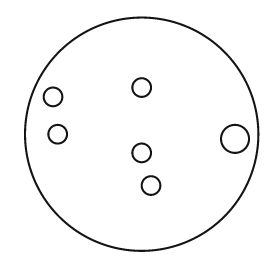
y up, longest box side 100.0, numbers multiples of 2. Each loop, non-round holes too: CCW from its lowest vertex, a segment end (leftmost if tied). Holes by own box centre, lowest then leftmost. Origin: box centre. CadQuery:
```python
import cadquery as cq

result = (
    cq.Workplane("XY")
    .moveTo(0.0, 0.0)
    .circle(50.0)
    .moveTo(4.0, -22.0)
    .circle(4.0)
    .moveTo(0.0, -8.0)
    .circle(4.0)
    .moveTo(40.0, -2.0)
    .circle(6.0)
    .moveTo(-36.0, 0.0)
    .circle(4.0)
    .moveTo(-38.0, 16.0)
    .circle(4.0)
    .moveTo(0.0, 20.0)
    .circle(4.0)
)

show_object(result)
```